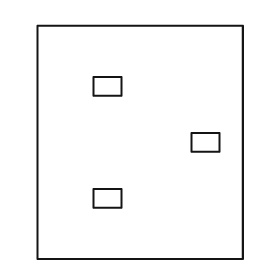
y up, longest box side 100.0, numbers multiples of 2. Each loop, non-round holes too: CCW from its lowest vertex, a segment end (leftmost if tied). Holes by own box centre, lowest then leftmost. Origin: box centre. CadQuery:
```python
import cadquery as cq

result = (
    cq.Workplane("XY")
    .moveTo(-44.0, -50.0)
    .lineTo(44.0, -50.0)
    .lineTo(44.0, 50.0)
    .lineTo(-44.0, 50.0)
    .close()
    .moveTo(-20.0, -28.0)
    .lineTo(-8.0, -28.0)
    .lineTo(-8.0, -20.0)
    .lineTo(-20.0, -20.0)
    .close()
    .moveTo(22.0, -4.0)
    .lineTo(34.0, -4.0)
    .lineTo(34.0, 4.0)
    .lineTo(22.0, 4.0)
    .close()
    .moveTo(-20.0, 20.0)
    .lineTo(-8.0, 20.0)
    .lineTo(-8.0, 28.0)
    .lineTo(-20.0, 28.0)
    .close()
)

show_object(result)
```